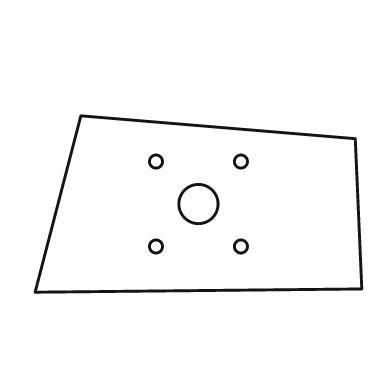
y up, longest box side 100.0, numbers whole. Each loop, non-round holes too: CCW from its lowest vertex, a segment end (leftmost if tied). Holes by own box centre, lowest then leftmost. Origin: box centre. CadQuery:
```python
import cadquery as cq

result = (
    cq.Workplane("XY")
    .moveTo(-50.0, -27.0)
    .lineTo(50.0, -26.0)
    .lineTo(48.0, 20.0)
    .lineTo(-36.0, 27.0)
    .close()
    .moveTo(-13.0, -13.0)
    .circle(2.0)
    .moveTo(13.0, -13.0)
    .circle(2.0)
    .moveTo(0.0, 0.0)
    .circle(6.0)
    .moveTo(-13.0, 13.0)
    .circle(2.0)
    .moveTo(13.0, 13.0)
    .circle(2.0)
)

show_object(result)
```